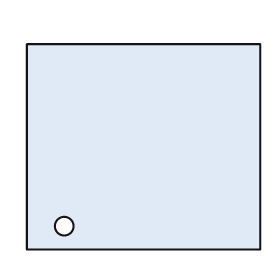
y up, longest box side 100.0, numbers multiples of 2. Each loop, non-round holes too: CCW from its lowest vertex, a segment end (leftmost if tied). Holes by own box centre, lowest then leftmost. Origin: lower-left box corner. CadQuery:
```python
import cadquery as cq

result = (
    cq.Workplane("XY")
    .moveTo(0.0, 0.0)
    .lineTo(100.0, 0.0)
    .lineTo(100.0, 88.0)
    .lineTo(0.0, 88.0)
    .close()
    .moveTo(16.0, 10.0)
    .circle(4.0)
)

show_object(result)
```